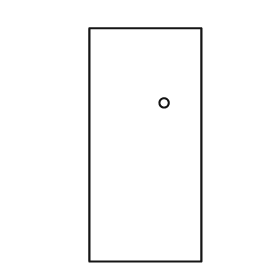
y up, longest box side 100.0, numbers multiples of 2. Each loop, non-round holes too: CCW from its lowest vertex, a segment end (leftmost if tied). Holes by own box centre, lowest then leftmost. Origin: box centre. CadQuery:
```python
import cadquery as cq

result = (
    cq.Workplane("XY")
    .moveTo(-24.0, -50.0)
    .lineTo(24.0, -50.0)
    .lineTo(24.0, 50.0)
    .lineTo(-24.0, 50.0)
    .close()
    .moveTo(8.0, 18.0)
    .circle(2.0)
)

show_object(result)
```